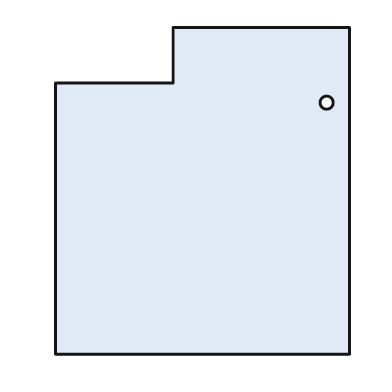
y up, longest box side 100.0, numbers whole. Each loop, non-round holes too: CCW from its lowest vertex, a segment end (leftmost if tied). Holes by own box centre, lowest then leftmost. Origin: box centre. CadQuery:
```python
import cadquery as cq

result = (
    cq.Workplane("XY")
    .moveTo(-45.0, -50.0)
    .lineTo(45.0, -50.0)
    .lineTo(45.0, 50.0)
    .lineTo(-9.0, 50.0)
    .lineTo(-9.0, 33.0)
    .lineTo(-45.0, 33.0)
    .close()
    .moveTo(38.0, 27.0)
    .circle(2.0)
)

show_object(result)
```